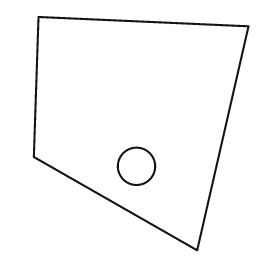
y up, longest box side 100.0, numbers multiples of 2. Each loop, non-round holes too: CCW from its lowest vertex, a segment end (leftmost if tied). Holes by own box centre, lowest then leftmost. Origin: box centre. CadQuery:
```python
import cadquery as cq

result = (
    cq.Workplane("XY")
    .moveTo(24.0, -50.0)
    .lineTo(46.0, 46.0)
    .lineTo(-44.0, 50.0)
    .lineTo(-46.0, -10.0)
    .close()
    .moveTo(-2.0, -14.0)
    .circle(8.0)
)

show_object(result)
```